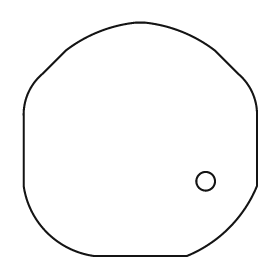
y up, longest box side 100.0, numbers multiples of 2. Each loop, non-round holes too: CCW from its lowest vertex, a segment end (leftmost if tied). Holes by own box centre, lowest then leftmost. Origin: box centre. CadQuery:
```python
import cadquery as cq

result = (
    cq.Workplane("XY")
    .moveTo(-20.0, -50.0)
    .lineTo(20.0, -50.0)
    .threePointArc((38.0, -38.0), (50.0, -20.0))
    .lineTo(50.0, 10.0)
    .threePointArc((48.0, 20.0), (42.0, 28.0))
    .lineTo(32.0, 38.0)
    .threePointArc((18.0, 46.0), (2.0, 50.0))
    .lineTo(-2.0, 50.0)
    .threePointArc((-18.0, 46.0), (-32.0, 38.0))
    .lineTo(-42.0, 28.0)
    .threePointArc((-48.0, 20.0), (-50.0, 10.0))
    .lineTo(-50.0, -20.0)
    .threePointArc((-40.0, -40.0), (-20.0, -50.0))
    .close()
    .moveTo(28.0, -18.0)
    .circle(4.0)
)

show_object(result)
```